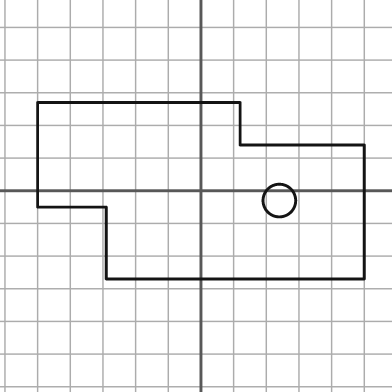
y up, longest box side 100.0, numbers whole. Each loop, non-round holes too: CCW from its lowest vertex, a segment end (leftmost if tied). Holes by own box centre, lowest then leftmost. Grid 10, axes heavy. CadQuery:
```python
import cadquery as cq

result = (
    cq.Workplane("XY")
    .moveTo(-29.0, -27.0)
    .lineTo(50.0, -27.0)
    .lineTo(50.0, 14.0)
    .lineTo(12.0, 14.0)
    .lineTo(12.0, 27.0)
    .lineTo(-50.0, 27.0)
    .lineTo(-50.0, -5.0)
    .lineTo(-29.0, -5.0)
    .close()
    .moveTo(24.0, -3.0)
    .circle(5.0)
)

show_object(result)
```